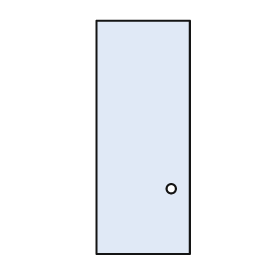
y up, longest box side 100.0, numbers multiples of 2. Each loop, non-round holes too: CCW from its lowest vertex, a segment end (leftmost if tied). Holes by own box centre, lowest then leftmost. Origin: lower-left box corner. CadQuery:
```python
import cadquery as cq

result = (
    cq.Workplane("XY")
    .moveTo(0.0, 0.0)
    .lineTo(40.0, 0.0)
    .lineTo(40.0, 100.0)
    .lineTo(0.0, 100.0)
    .close()
    .moveTo(32.0, 28.0)
    .circle(2.0)
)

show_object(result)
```